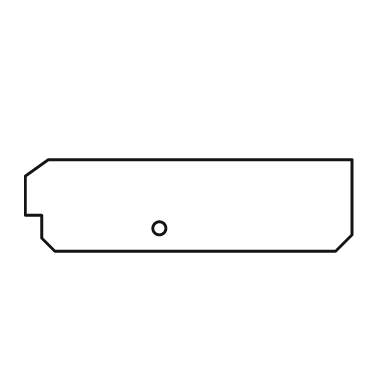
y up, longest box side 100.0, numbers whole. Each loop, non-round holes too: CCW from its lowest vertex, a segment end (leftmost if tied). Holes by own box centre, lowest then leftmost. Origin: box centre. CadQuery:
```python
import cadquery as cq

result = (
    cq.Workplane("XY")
    .moveTo(-41.0, -14.0)
    .lineTo(45.0, -14.0)
    .lineTo(50.0, -9.0)
    .lineTo(50.0, 14.0)
    .lineTo(-43.0, 14.0)
    .lineTo(-50.0, 9.0)
    .lineTo(-50.0, -3.0)
    .lineTo(-45.0, -3.0)
    .lineTo(-45.0, -10.0)
    .close()
    .moveTo(-9.0, -7.0)
    .circle(2.0)
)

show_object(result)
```